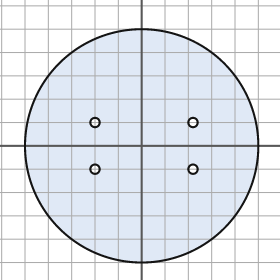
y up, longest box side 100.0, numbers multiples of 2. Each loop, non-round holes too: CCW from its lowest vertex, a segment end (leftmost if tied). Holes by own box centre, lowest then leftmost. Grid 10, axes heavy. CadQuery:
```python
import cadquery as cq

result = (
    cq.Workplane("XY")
    .moveTo(0.0, 0.0)
    .circle(50.0)
    .moveTo(-20.0, -10.0)
    .circle(2.0)
    .moveTo(22.0, -10.0)
    .circle(2.0)
    .moveTo(-20.0, 10.0)
    .circle(2.0)
    .moveTo(22.0, 10.0)
    .circle(2.0)
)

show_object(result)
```